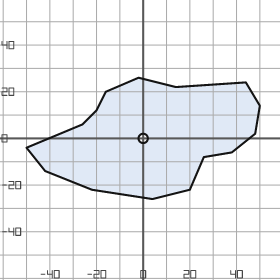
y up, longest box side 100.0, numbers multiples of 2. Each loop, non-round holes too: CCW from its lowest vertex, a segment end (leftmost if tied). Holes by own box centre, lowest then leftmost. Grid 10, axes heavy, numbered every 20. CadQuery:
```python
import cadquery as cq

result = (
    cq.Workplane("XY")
    .moveTo(4.0, -26.0)
    .lineTo(20.0, -22.0)
    .lineTo(26.0, -8.0)
    .lineTo(38.0, -6.0)
    .lineTo(48.0, 2.0)
    .lineTo(50.0, 14.0)
    .lineTo(44.0, 24.0)
    .lineTo(14.0, 22.0)
    .lineTo(-2.0, 26.0)
    .lineTo(-16.0, 20.0)
    .lineTo(-20.0, 12.0)
    .lineTo(-26.0, 6.0)
    .lineTo(-50.0, -4.0)
    .lineTo(-42.0, -14.0)
    .lineTo(-22.0, -22.0)
    .close()
    .moveTo(0.0, 0.0)
    .circle(2.0)
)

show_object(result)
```